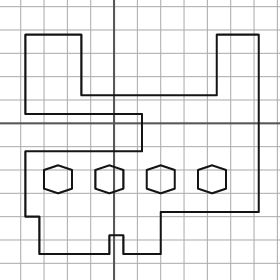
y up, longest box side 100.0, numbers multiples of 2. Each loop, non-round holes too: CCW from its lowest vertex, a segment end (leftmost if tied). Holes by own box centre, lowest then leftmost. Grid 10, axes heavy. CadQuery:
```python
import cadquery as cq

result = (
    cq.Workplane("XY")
    .moveTo(-32.0, -56.0)
    .lineTo(-2.0, -56.0)
    .lineTo(-2.0, -48.0)
    .lineTo(4.0, -48.0)
    .lineTo(4.0, -56.0)
    .lineTo(20.0, -56.0)
    .lineTo(20.0, -38.0)
    .lineTo(62.0, -38.0)
    .lineTo(62.0, 38.0)
    .lineTo(44.0, 38.0)
    .lineTo(44.0, 12.0)
    .lineTo(-14.0, 12.0)
    .lineTo(-14.0, 38.0)
    .lineTo(-38.0, 38.0)
    .lineTo(-38.0, 4.0)
    .lineTo(12.0, 4.0)
    .lineTo(12.0, -12.0)
    .lineTo(-38.0, -12.0)
    .lineTo(-38.0, -40.0)
    .lineTo(-32.0, -40.0)
    .close()
    .moveTo(-24.0, -30.0)
    .lineTo(-18.0, -28.0)
    .lineTo(-18.0, -20.0)
    .lineTo(-24.0, -18.0)
    .lineTo(-30.0, -20.0)
    .lineTo(-30.0, -28.0)
    .close()
    .moveTo(-2.0, -30.0)
    .lineTo(4.0, -28.0)
    .lineTo(4.0, -20.0)
    .lineTo(-2.0, -18.0)
    .lineTo(-8.0, -20.0)
    .lineTo(-8.0, -28.0)
    .close()
    .moveTo(20.0, -30.0)
    .lineTo(26.0, -28.0)
    .lineTo(26.0, -20.0)
    .lineTo(20.0, -18.0)
    .lineTo(14.0, -20.0)
    .lineTo(14.0, -28.0)
    .close()
    .moveTo(42.0, -30.0)
    .lineTo(48.0, -28.0)
    .lineTo(48.0, -20.0)
    .lineTo(42.0, -18.0)
    .lineTo(36.0, -20.0)
    .lineTo(36.0, -28.0)
    .close()
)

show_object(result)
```